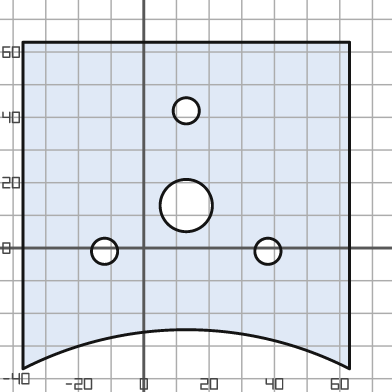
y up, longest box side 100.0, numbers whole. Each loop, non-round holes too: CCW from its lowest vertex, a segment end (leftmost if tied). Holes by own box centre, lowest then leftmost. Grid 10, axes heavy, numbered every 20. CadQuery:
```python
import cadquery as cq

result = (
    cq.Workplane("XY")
    .moveTo(-37.0, -37.0)
    .threePointArc((13.0, -25.0), (63.0, -37.0))
    .lineTo(63.0, 63.0)
    .lineTo(-37.0, 63.0)
    .close()
    .moveTo(-12.0, -1.0)
    .circle(4.0)
    .moveTo(38.0, -1.0)
    .circle(4.0)
    .moveTo(13.0, 13.0)
    .circle(8.0)
    .moveTo(13.0, 42.0)
    .circle(4.0)
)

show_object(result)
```